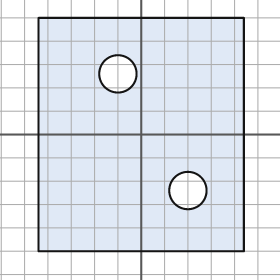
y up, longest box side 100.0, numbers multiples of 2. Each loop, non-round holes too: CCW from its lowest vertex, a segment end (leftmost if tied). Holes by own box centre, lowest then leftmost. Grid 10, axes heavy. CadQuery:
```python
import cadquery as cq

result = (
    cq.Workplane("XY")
    .moveTo(-44.0, -50.0)
    .lineTo(44.0, -50.0)
    .lineTo(44.0, 50.0)
    .lineTo(-44.0, 50.0)
    .close()
    .moveTo(20.0, -24.0)
    .circle(8.0)
    .moveTo(-10.0, 26.0)
    .circle(8.0)
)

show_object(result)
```